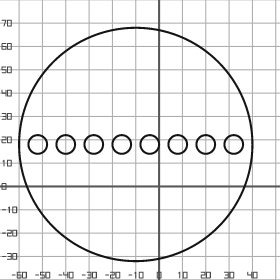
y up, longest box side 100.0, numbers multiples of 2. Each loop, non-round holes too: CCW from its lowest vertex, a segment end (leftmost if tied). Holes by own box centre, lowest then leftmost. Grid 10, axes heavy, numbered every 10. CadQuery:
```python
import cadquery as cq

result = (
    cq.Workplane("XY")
    .moveTo(-10.0, 18.0)
    .circle(50.0)
    .moveTo(-52.0, 18.0)
    .circle(4.0)
    .moveTo(-40.0, 18.0)
    .circle(4.0)
    .moveTo(-28.0, 18.0)
    .circle(4.0)
    .moveTo(-16.0, 18.0)
    .circle(4.0)
    .moveTo(-4.0, 18.0)
    .circle(4.0)
    .moveTo(8.0, 18.0)
    .circle(4.0)
    .moveTo(20.0, 18.0)
    .circle(4.0)
    .moveTo(32.0, 18.0)
    .circle(4.0)
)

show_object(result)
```